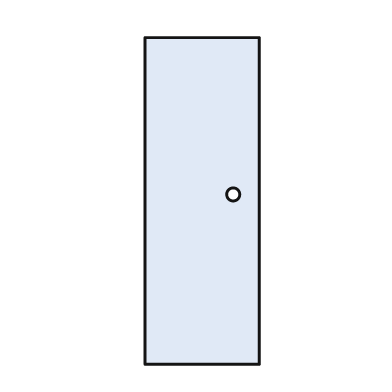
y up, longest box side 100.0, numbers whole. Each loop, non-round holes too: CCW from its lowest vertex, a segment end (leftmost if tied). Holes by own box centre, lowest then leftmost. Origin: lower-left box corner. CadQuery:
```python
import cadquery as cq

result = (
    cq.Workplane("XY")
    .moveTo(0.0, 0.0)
    .lineTo(35.0, 0.0)
    .lineTo(35.0, 100.0)
    .lineTo(0.0, 100.0)
    .close()
    .moveTo(27.0, 52.0)
    .circle(2.0)
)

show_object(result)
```